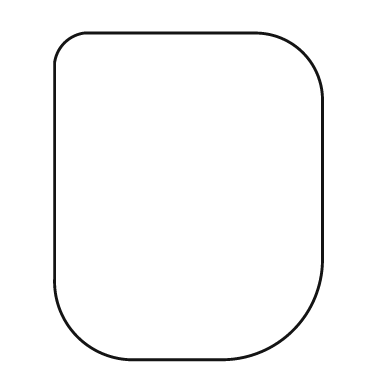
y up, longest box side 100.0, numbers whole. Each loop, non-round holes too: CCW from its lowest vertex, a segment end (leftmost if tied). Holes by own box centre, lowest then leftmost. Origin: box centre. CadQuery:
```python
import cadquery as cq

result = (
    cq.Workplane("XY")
    .moveTo(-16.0, -50.0)
    .lineTo(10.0, -50.0)
    .threePointArc((32.0, -41.0), (41.0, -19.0))
    .lineTo(41.0, 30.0)
    .threePointArc((35.0, 44.0), (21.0, 50.0))
    .lineTo(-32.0, 50.0)
    .threePointArc((-38.0, 47.0), (-41.0, 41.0))
    .lineTo(-41.0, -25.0)
    .threePointArc((-34.0, -43.0), (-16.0, -50.0))
    .close()
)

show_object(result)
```